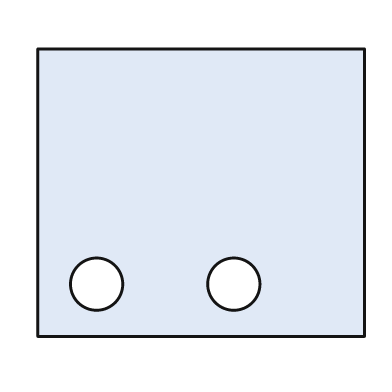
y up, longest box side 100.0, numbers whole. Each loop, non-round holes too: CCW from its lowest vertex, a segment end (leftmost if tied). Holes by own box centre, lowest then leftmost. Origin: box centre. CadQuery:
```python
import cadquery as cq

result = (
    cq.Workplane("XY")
    .moveTo(-50.0, -44.0)
    .lineTo(50.0, -44.0)
    .lineTo(50.0, 44.0)
    .lineTo(-50.0, 44.0)
    .close()
    .moveTo(-32.0, -28.0)
    .circle(8.0)
    .moveTo(10.0, -28.0)
    .circle(8.0)
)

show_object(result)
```